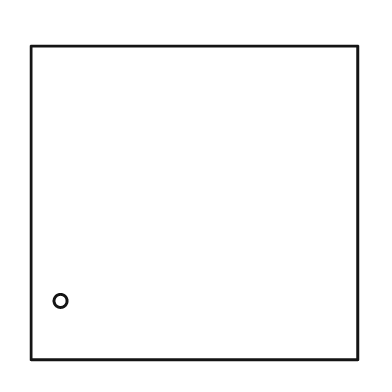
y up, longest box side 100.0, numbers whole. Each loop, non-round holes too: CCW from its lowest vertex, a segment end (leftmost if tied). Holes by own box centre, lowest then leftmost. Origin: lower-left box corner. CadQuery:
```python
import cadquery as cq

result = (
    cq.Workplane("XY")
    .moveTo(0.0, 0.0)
    .lineTo(100.0, 0.0)
    .lineTo(100.0, 96.0)
    .lineTo(0.0, 96.0)
    .close()
    .moveTo(9.0, 18.0)
    .circle(2.0)
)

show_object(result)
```